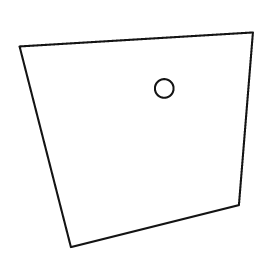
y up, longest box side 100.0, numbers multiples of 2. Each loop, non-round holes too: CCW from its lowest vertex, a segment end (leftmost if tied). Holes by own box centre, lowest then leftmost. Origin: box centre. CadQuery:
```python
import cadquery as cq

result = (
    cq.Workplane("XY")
    .moveTo(-28.0, -46.0)
    .lineTo(44.0, -28.0)
    .lineTo(50.0, 46.0)
    .lineTo(-50.0, 40.0)
    .close()
    .moveTo(12.0, 22.0)
    .circle(4.0)
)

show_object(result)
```